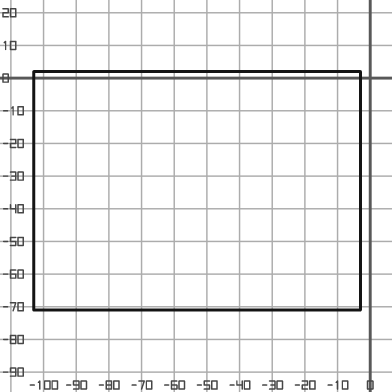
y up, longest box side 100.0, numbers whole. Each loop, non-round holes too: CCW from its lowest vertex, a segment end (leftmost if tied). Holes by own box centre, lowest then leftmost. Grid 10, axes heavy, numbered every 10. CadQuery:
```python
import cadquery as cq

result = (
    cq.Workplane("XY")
    .moveTo(-103.0, -71.0)
    .lineTo(-3.0, -71.0)
    .lineTo(-3.0, 2.0)
    .lineTo(-103.0, 2.0)
    .close()
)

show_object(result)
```